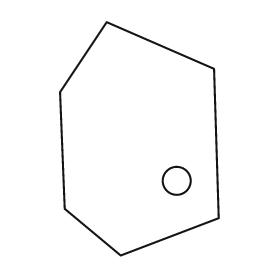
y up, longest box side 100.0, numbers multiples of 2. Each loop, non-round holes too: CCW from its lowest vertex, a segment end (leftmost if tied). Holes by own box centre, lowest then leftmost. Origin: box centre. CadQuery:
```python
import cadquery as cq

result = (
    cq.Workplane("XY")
    .moveTo(-8.0, -50.0)
    .lineTo(34.0, -34.0)
    .lineTo(32.0, 30.0)
    .lineTo(-14.0, 50.0)
    .lineTo(-34.0, 20.0)
    .lineTo(-32.0, -30.0)
    .close()
    .moveTo(16.0, -18.0)
    .circle(6.0)
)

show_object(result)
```